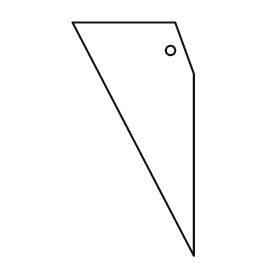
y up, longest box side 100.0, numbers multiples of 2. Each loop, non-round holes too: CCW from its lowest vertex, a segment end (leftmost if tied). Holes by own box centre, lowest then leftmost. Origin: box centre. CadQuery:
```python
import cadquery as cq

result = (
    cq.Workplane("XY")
    .moveTo(26.0, -50.0)
    .lineTo(26.0, 28.0)
    .lineTo(18.0, 50.0)
    .lineTo(-26.0, 50.0)
    .close()
    .moveTo(16.0, 38.0)
    .circle(2.0)
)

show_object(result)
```